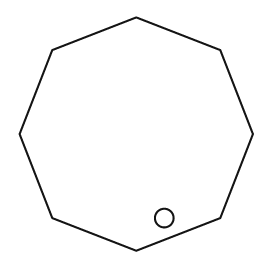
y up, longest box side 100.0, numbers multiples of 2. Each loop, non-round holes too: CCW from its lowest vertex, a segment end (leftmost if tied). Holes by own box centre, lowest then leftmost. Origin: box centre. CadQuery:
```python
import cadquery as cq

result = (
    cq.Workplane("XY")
    .moveTo(0.0, -50.0)
    .lineTo(36.0, -36.0)
    .lineTo(50.0, 0.0)
    .lineTo(36.0, 36.0)
    .lineTo(0.0, 50.0)
    .lineTo(-36.0, 36.0)
    .lineTo(-50.0, 0.0)
    .lineTo(-36.0, -36.0)
    .close()
    .moveTo(12.0, -36.0)
    .circle(4.0)
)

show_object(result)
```